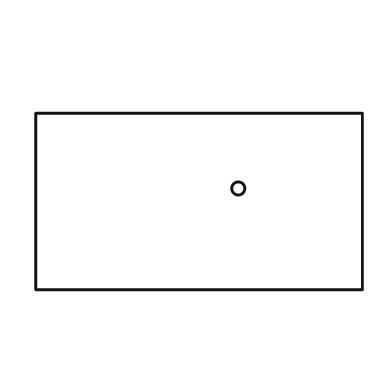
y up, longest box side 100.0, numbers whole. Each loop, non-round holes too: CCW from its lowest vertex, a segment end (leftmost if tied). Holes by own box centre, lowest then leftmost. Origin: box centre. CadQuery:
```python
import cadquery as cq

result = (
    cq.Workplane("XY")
    .moveTo(-50.0, -27.0)
    .lineTo(50.0, -27.0)
    .lineTo(50.0, 27.0)
    .lineTo(-50.0, 27.0)
    .close()
    .moveTo(12.0, 4.0)
    .circle(2.0)
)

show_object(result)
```